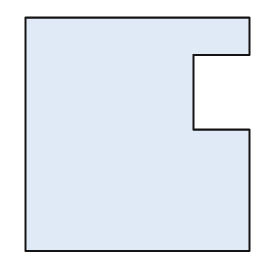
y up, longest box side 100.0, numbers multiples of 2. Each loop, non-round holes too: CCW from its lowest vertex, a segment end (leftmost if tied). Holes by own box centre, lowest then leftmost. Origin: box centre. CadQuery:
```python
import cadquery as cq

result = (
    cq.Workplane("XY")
    .moveTo(-48.0, -50.0)
    .lineTo(48.0, -50.0)
    .lineTo(48.0, 2.0)
    .lineTo(24.0, 2.0)
    .lineTo(24.0, 34.0)
    .lineTo(48.0, 34.0)
    .lineTo(48.0, 50.0)
    .lineTo(-48.0, 50.0)
    .close()
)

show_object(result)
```